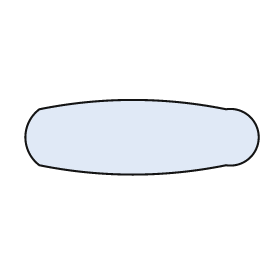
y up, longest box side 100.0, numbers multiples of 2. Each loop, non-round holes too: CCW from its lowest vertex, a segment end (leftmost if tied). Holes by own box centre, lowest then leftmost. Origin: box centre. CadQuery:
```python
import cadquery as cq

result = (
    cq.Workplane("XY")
    .moveTo(-44.0, -12.0)
    .threePointArc((-4.0, -16.0), (36.0, -12.0))
    .threePointArc((50.0, 0.0), (36.0, 12.0))
    .threePointArc((-4.0, 16.0), (-44.0, 12.0))
    .threePointArc((-50.0, 0.0), (-44.0, -12.0))
    .close()
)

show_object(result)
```